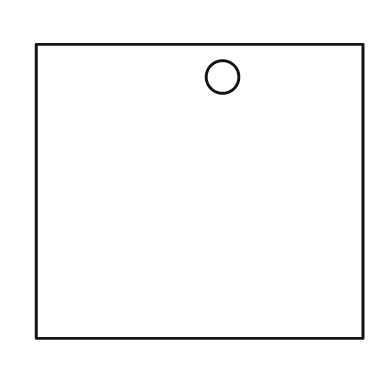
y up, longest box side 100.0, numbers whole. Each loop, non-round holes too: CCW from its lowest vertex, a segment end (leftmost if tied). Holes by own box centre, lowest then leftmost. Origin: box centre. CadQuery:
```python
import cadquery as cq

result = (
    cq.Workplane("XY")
    .moveTo(-50.0, -45.0)
    .lineTo(50.0, -45.0)
    .lineTo(50.0, 45.0)
    .lineTo(-50.0, 45.0)
    .close()
    .moveTo(7.0, 35.0)
    .circle(5.0)
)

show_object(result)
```